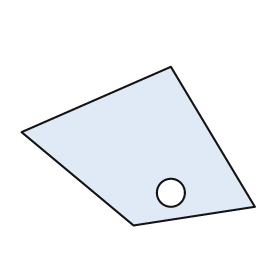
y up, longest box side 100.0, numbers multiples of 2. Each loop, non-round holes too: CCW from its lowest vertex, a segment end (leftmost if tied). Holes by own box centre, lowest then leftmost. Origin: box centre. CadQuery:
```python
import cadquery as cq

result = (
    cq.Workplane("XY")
    .moveTo(-2.0, -34.0)
    .lineTo(50.0, -26.0)
    .lineTo(14.0, 34.0)
    .lineTo(-50.0, 6.0)
    .close()
    .moveTo(14.0, -20.0)
    .circle(6.0)
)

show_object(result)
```